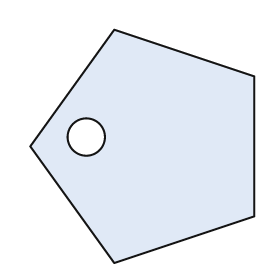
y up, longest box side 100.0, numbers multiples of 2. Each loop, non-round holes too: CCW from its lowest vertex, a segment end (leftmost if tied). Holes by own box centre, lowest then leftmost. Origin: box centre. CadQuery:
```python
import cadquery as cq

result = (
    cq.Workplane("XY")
    .moveTo(-12.0, -50.0)
    .lineTo(48.0, -30.0)
    .lineTo(48.0, 30.0)
    .lineTo(-12.0, 50.0)
    .lineTo(-48.0, 0.0)
    .close()
    .moveTo(-24.0, 4.0)
    .circle(8.0)
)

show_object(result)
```